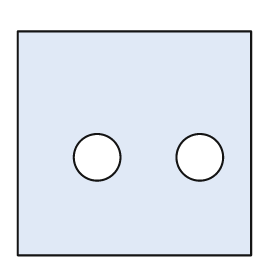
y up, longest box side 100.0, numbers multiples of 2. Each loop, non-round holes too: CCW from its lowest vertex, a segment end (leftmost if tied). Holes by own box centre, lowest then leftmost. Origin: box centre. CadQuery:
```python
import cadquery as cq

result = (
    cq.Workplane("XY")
    .moveTo(-50.0, -48.0)
    .lineTo(50.0, -48.0)
    .lineTo(50.0, 48.0)
    .lineTo(-50.0, 48.0)
    .close()
    .moveTo(-16.0, -6.0)
    .circle(10.0)
    .moveTo(28.0, -6.0)
    .circle(10.0)
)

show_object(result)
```